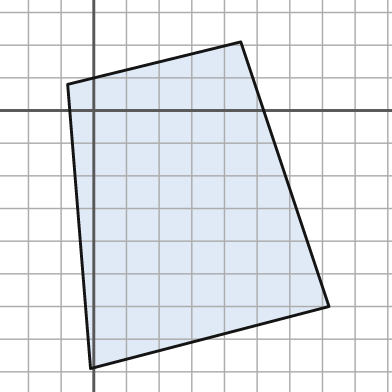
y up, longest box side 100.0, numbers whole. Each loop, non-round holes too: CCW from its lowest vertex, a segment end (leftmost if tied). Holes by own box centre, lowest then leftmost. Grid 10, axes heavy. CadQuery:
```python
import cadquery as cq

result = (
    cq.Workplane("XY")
    .moveTo(-1.0, -79.0)
    .lineTo(72.0, -60.0)
    .lineTo(45.0, 21.0)
    .lineTo(-8.0, 8.0)
    .close()
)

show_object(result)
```